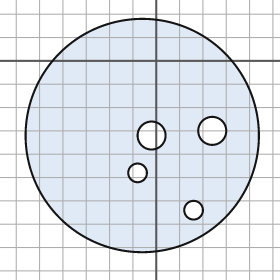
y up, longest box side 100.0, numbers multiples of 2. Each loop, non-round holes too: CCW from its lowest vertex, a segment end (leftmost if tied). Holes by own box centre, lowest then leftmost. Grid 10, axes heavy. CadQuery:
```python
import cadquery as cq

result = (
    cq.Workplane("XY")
    .moveTo(-6.0, -32.0)
    .circle(50.0)
    .moveTo(16.0, -64.0)
    .circle(4.0)
    .moveTo(-8.0, -48.0)
    .circle(4.0)
    .moveTo(-2.0, -32.0)
    .circle(6.0)
    .moveTo(24.0, -30.0)
    .circle(6.0)
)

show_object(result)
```